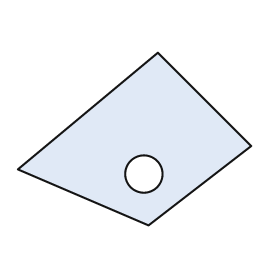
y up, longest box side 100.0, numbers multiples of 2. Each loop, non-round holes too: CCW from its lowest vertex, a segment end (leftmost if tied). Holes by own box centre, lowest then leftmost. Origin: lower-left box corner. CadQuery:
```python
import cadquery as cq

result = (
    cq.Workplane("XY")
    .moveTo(56.0, 0.0)
    .lineTo(100.0, 34.0)
    .lineTo(60.0, 74.0)
    .lineTo(0.0, 24.0)
    .close()
    .moveTo(54.0, 22.0)
    .circle(8.0)
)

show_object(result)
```